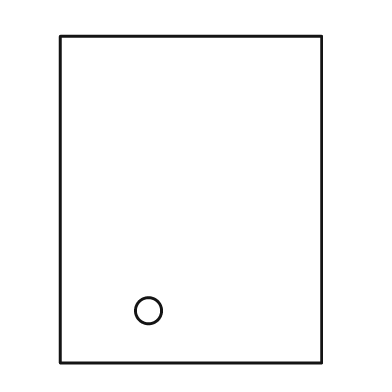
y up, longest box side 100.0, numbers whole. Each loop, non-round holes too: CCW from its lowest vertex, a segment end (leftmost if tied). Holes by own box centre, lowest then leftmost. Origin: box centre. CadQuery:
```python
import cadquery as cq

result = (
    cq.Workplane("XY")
    .moveTo(-40.0, -50.0)
    .lineTo(40.0, -50.0)
    .lineTo(40.0, 50.0)
    .lineTo(-40.0, 50.0)
    .close()
    .moveTo(-13.0, -34.0)
    .circle(4.0)
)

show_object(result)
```